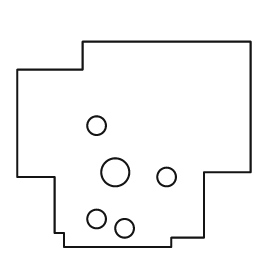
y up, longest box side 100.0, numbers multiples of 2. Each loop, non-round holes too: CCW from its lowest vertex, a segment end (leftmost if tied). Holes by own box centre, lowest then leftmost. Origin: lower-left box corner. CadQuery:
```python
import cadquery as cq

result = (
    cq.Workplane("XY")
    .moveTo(20.0, 0.0)
    .lineTo(66.0, 0.0)
    .lineTo(66.0, 4.0)
    .lineTo(80.0, 4.0)
    .lineTo(80.0, 32.0)
    .lineTo(100.0, 32.0)
    .lineTo(100.0, 88.0)
    .lineTo(28.0, 88.0)
    .lineTo(28.0, 76.0)
    .lineTo(0.0, 76.0)
    .lineTo(0.0, 30.0)
    .lineTo(16.0, 30.0)
    .lineTo(16.0, 6.0)
    .lineTo(20.0, 6.0)
    .close()
    .moveTo(46.0, 8.0)
    .circle(4.0)
    .moveTo(34.0, 12.0)
    .circle(4.0)
    .moveTo(64.0, 30.0)
    .circle(4.0)
    .moveTo(42.0, 32.0)
    .circle(6.0)
    .moveTo(34.0, 52.0)
    .circle(4.0)
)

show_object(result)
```